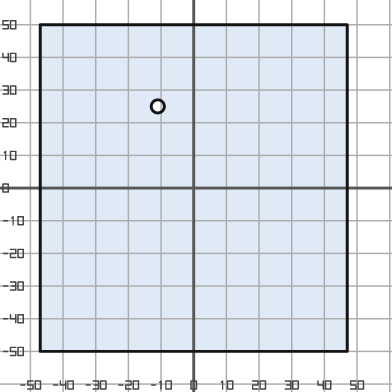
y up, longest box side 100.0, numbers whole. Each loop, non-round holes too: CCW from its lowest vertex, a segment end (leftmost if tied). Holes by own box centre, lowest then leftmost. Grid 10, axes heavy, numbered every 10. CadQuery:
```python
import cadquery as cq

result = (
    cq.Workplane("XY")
    .moveTo(-47.0, -50.0)
    .lineTo(47.0, -50.0)
    .lineTo(47.0, 50.0)
    .lineTo(-47.0, 50.0)
    .close()
    .moveTo(-11.0, 25.0)
    .circle(2.0)
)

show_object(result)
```